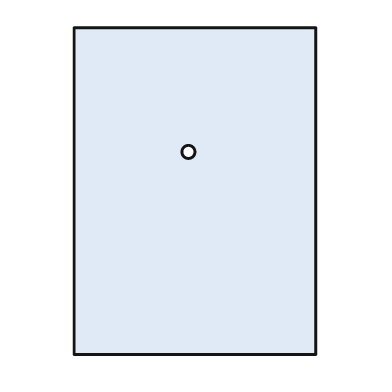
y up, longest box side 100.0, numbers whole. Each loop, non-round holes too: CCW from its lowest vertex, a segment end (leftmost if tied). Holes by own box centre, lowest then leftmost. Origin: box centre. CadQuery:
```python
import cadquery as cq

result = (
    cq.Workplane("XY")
    .moveTo(-37.0, -50.0)
    .lineTo(37.0, -50.0)
    .lineTo(37.0, 50.0)
    .lineTo(-37.0, 50.0)
    .close()
    .moveTo(-2.0, 12.0)
    .circle(2.0)
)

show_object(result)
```